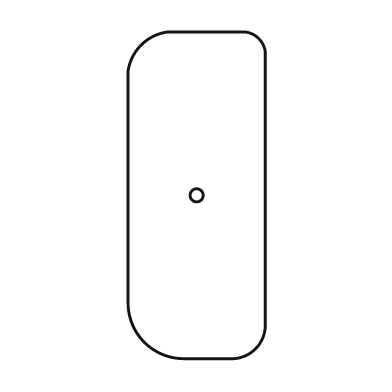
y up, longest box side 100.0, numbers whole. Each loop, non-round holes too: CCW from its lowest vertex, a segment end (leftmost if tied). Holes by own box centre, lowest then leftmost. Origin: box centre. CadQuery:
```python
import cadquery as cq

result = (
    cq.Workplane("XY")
    .moveTo(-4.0, -50.0)
    .lineTo(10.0, -50.0)
    .threePointArc((18.0, -47.0), (21.0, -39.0))
    .lineTo(21.0, 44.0)
    .threePointArc((19.0, 48.0), (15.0, 50.0))
    .lineTo(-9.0, 50.0)
    .threePointArc((-17.0, 46.0), (-21.0, 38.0))
    .lineTo(-21.0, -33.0)
    .threePointArc((-16.0, -45.0), (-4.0, -50.0))
    .close()
    .moveTo(0.0, 0.0)
    .circle(2.0)
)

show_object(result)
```